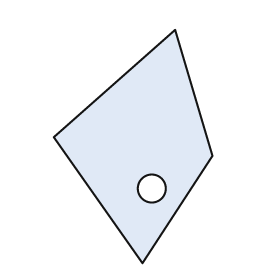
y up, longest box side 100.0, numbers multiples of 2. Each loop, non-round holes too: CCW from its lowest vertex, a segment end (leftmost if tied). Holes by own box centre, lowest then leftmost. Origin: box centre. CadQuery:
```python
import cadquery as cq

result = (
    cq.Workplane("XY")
    .moveTo(4.0, -50.0)
    .lineTo(34.0, -4.0)
    .lineTo(18.0, 50.0)
    .lineTo(-34.0, 4.0)
    .close()
    .moveTo(8.0, -18.0)
    .circle(6.0)
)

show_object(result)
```